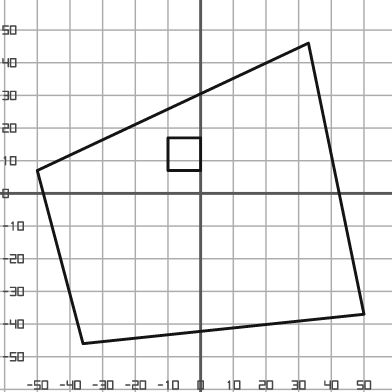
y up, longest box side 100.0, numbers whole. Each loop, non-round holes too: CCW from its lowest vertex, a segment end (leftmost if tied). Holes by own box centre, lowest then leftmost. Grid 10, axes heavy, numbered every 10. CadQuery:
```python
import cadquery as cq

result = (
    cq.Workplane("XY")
    .moveTo(-36.0, -46.0)
    .lineTo(50.0, -37.0)
    .lineTo(33.0, 46.0)
    .lineTo(-50.0, 7.0)
    .close()
    .moveTo(-10.0, 7.0)
    .lineTo(0.0, 7.0)
    .lineTo(0.0, 17.0)
    .lineTo(-10.0, 17.0)
    .close()
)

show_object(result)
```